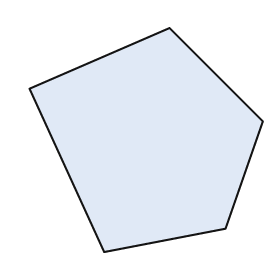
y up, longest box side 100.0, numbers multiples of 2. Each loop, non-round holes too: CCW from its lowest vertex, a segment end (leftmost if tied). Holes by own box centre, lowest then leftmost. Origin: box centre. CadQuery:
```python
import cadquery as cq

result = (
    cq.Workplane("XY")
    .moveTo(-18.0, -48.0)
    .lineTo(34.0, -38.0)
    .lineTo(50.0, 8.0)
    .lineTo(10.0, 48.0)
    .lineTo(-50.0, 22.0)
    .close()
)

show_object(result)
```